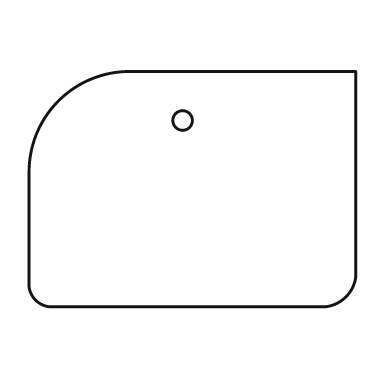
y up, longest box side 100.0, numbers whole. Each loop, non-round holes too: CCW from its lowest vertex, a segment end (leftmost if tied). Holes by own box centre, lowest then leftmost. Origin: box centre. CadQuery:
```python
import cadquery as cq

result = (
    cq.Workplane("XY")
    .moveTo(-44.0, -36.0)
    .lineTo(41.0, -36.0)
    .threePointArc((47.0, -33.0), (50.0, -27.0))
    .lineTo(50.0, 36.0)
    .lineTo(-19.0, 36.0)
    .threePointArc((-41.0, 27.0), (-50.0, 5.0))
    .lineTo(-50.0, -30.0)
    .threePointArc((-48.0, -34.0), (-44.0, -36.0))
    .close()
    .moveTo(-3.0, 21.0)
    .circle(3.0)
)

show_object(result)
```